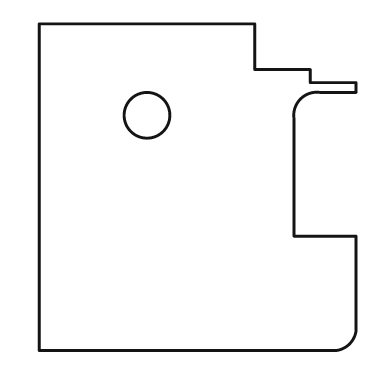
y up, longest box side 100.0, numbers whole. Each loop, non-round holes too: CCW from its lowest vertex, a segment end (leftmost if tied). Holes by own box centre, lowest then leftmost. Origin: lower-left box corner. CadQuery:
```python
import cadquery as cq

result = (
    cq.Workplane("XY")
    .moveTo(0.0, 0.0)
    .lineTo(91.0, 0.0)
    .threePointArc((95.0, 2.0), (97.0, 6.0))
    .lineTo(97.0, 35.0)
    .lineTo(78.0, 35.0)
    .lineTo(78.0, 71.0)
    .threePointArc((80.0, 77.0), (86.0, 79.0))
    .lineTo(97.0, 79.0)
    .lineTo(97.0, 82.0)
    .lineTo(83.0, 82.0)
    .lineTo(83.0, 86.0)
    .lineTo(66.0, 86.0)
    .lineTo(66.0, 100.0)
    .lineTo(0.0, 100.0)
    .close()
    .moveTo(33.0, 72.0)
    .circle(7.0)
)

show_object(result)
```